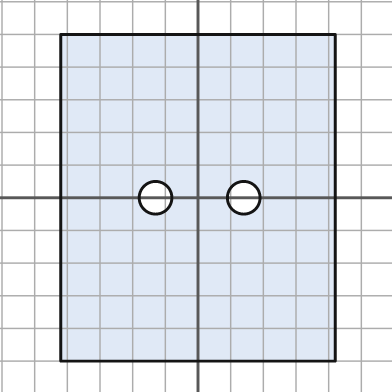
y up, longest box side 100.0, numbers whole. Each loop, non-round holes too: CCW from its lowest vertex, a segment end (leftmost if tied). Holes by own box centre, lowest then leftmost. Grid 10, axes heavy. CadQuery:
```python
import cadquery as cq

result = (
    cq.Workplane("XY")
    .moveTo(-42.0, -50.0)
    .lineTo(42.0, -50.0)
    .lineTo(42.0, 50.0)
    .lineTo(-42.0, 50.0)
    .close()
    .moveTo(-13.0, 0.0)
    .circle(5.0)
    .moveTo(14.0, 0.0)
    .circle(5.0)
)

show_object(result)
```